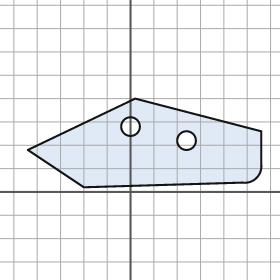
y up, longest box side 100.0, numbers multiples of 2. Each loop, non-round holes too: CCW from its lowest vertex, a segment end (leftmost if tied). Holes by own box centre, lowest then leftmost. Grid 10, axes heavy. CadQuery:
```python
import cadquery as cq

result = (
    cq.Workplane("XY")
    .moveTo(-20.0, 2.0)
    .lineTo(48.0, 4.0)
    .threePointArc((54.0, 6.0), (56.0, 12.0))
    .lineTo(56.0, 26.0)
    .lineTo(2.0, 40.0)
    .lineTo(-44.0, 18.0)
    .close()
    .moveTo(24.0, 22.0)
    .circle(4.0)
    .moveTo(0.0, 28.0)
    .circle(4.0)
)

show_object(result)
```